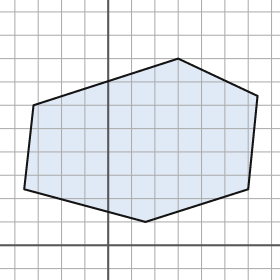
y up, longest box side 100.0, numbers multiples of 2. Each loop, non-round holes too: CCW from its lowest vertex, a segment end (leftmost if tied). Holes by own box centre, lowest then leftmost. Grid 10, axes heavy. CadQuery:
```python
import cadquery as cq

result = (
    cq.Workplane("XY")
    .moveTo(16.0, 10.0)
    .lineTo(60.0, 24.0)
    .lineTo(64.0, 64.0)
    .lineTo(30.0, 80.0)
    .lineTo(-32.0, 60.0)
    .lineTo(-36.0, 24.0)
    .close()
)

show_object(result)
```